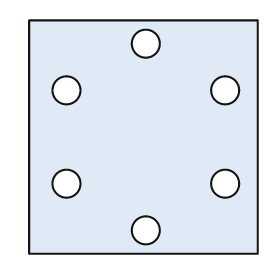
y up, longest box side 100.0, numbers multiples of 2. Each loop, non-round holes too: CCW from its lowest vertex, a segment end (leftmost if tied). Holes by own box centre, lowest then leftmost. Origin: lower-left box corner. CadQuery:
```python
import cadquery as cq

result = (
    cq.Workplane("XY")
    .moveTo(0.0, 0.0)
    .lineTo(98.0, 0.0)
    .lineTo(98.0, 100.0)
    .lineTo(0.0, 100.0)
    .close()
    .moveTo(50.0, 10.0)
    .circle(6.0)
    .moveTo(16.0, 30.0)
    .circle(6.0)
    .moveTo(84.0, 30.0)
    .circle(6.0)
    .moveTo(16.0, 70.0)
    .circle(6.0)
    .moveTo(84.0, 70.0)
    .circle(6.0)
    .moveTo(50.0, 90.0)
    .circle(6.0)
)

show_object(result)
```